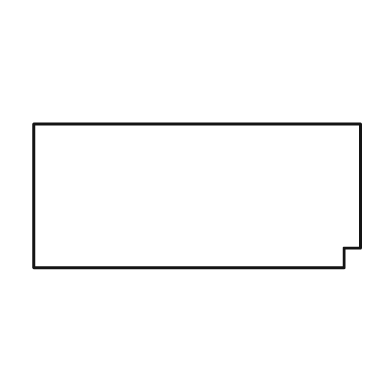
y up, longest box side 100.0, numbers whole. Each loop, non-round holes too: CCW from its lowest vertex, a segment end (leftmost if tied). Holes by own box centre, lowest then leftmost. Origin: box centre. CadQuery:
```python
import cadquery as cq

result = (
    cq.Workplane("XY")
    .moveTo(-50.0, -22.0)
    .lineTo(45.0, -22.0)
    .lineTo(45.0, -16.0)
    .lineTo(50.0, -16.0)
    .lineTo(50.0, 22.0)
    .lineTo(-50.0, 22.0)
    .close()
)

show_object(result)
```